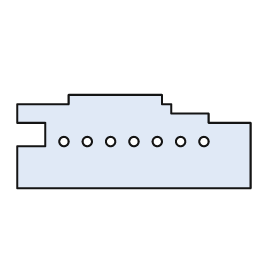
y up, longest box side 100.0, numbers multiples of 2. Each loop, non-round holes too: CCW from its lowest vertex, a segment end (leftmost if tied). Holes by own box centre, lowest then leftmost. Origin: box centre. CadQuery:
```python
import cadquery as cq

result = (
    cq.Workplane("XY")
    .moveTo(-50.0, -20.0)
    .lineTo(50.0, -20.0)
    .lineTo(50.0, 8.0)
    .lineTo(32.0, 8.0)
    .lineTo(32.0, 12.0)
    .lineTo(16.0, 12.0)
    .lineTo(16.0, 16.0)
    .lineTo(12.0, 16.0)
    .lineTo(12.0, 20.0)
    .lineTo(-28.0, 20.0)
    .lineTo(-28.0, 16.0)
    .lineTo(-50.0, 16.0)
    .lineTo(-50.0, 8.0)
    .lineTo(-38.0, 8.0)
    .lineTo(-38.0, -2.0)
    .lineTo(-50.0, -2.0)
    .close()
    .moveTo(-30.0, 0.0)
    .circle(2.0)
    .moveTo(-20.0, 0.0)
    .circle(2.0)
    .moveTo(-10.0, 0.0)
    .circle(2.0)
    .moveTo(0.0, 0.0)
    .circle(2.0)
    .moveTo(10.0, 0.0)
    .circle(2.0)
    .moveTo(20.0, 0.0)
    .circle(2.0)
    .moveTo(30.0, 0.0)
    .circle(2.0)
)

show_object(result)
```